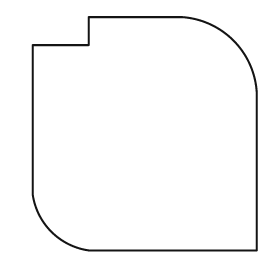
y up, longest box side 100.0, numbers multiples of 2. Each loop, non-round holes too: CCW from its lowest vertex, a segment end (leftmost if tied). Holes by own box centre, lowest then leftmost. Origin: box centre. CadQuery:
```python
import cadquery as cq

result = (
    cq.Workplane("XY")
    .moveTo(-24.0, -50.0)
    .lineTo(48.0, -50.0)
    .lineTo(48.0, 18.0)
    .threePointArc((38.0, 40.0), (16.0, 50.0))
    .lineTo(-24.0, 50.0)
    .lineTo(-24.0, 38.0)
    .lineTo(-48.0, 38.0)
    .lineTo(-48.0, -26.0)
    .threePointArc((-40.0, -42.0), (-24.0, -50.0))
    .close()
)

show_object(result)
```